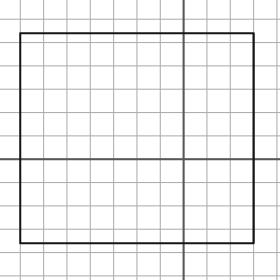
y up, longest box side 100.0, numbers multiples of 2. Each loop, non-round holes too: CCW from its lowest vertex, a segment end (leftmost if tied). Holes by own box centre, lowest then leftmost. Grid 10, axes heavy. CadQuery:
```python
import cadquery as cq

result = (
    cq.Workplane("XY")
    .moveTo(-70.0, -36.0)
    .lineTo(30.0, -36.0)
    .lineTo(30.0, 54.0)
    .lineTo(-70.0, 54.0)
    .close()
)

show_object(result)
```